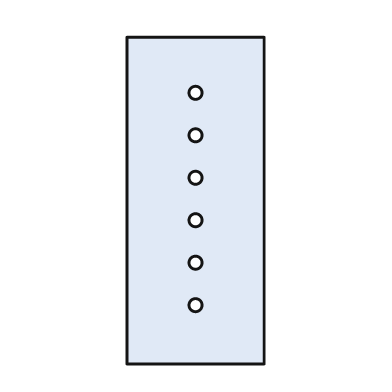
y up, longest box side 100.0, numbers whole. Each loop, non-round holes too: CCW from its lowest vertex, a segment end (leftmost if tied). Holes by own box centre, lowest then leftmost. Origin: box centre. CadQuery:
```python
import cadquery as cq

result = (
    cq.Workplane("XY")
    .moveTo(-21.0, -50.0)
    .lineTo(21.0, -50.0)
    .lineTo(21.0, 50.0)
    .lineTo(-21.0, 50.0)
    .close()
    .moveTo(0.0, -32.0)
    .circle(2.0)
    .moveTo(0.0, -19.0)
    .circle(2.0)
    .moveTo(0.0, -6.0)
    .circle(2.0)
    .moveTo(0.0, 7.0)
    .circle(2.0)
    .moveTo(0.0, 20.0)
    .circle(2.0)
    .moveTo(0.0, 33.0)
    .circle(2.0)
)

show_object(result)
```